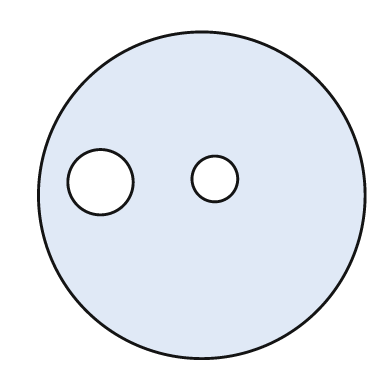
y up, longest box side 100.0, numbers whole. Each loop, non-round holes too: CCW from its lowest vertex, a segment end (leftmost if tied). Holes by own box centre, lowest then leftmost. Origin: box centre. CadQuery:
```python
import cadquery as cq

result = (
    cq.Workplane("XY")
    .moveTo(0.0, 0.0)
    .circle(50.0)
    .moveTo(-31.0, 4.0)
    .circle(10.0)
    .moveTo(4.0, 5.0)
    .circle(7.0)
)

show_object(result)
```